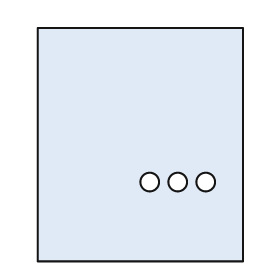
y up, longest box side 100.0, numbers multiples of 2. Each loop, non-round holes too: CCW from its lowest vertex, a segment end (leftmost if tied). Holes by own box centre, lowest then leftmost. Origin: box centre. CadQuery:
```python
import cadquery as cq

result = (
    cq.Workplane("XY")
    .moveTo(-44.0, -50.0)
    .lineTo(44.0, -50.0)
    .lineTo(44.0, 50.0)
    .lineTo(-44.0, 50.0)
    .close()
    .moveTo(4.0, -16.0)
    .circle(4.0)
    .moveTo(16.0, -16.0)
    .circle(4.0)
    .moveTo(28.0, -16.0)
    .circle(4.0)
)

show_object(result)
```